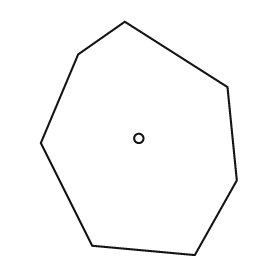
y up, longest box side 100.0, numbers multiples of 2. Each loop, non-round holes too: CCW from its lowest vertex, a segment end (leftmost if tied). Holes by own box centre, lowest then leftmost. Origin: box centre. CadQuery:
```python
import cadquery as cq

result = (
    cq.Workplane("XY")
    .moveTo(24.0, -50.0)
    .lineTo(42.0, -18.0)
    .lineTo(38.0, 22.0)
    .lineTo(-6.0, 50.0)
    .lineTo(-26.0, 36.0)
    .lineTo(-42.0, -2.0)
    .lineTo(-20.0, -46.0)
    .close()
    .moveTo(0.0, 0.0)
    .circle(2.0)
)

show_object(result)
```